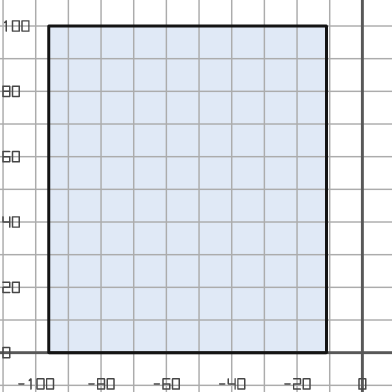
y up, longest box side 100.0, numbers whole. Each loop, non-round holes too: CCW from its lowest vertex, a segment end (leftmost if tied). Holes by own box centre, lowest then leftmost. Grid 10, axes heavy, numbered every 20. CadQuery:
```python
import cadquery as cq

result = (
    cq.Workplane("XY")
    .moveTo(-96.0, 0.0)
    .lineTo(-11.0, 0.0)
    .lineTo(-11.0, 100.0)
    .lineTo(-96.0, 100.0)
    .close()
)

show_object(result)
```